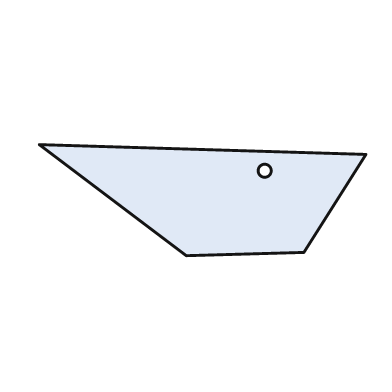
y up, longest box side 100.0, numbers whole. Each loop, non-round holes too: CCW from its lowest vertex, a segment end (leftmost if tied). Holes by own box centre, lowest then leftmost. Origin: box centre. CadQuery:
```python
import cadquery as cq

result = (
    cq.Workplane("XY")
    .moveTo(-5.0, -17.0)
    .lineTo(31.0, -16.0)
    .lineTo(50.0, 14.0)
    .lineTo(-50.0, 17.0)
    .close()
    .moveTo(19.0, 9.0)
    .circle(2.0)
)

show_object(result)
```